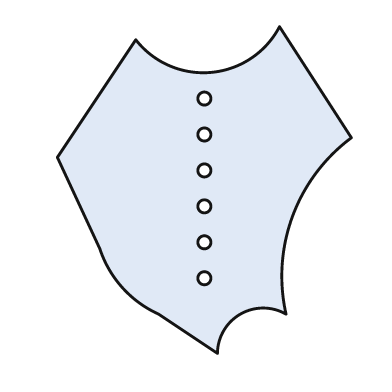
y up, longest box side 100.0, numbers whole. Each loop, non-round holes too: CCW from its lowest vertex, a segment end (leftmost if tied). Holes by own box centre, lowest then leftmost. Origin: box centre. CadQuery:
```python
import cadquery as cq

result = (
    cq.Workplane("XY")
    .moveTo(4.0, -50.0)
    .threePointArc((11.0, -38.0), (25.0, -38.0))
    .threePointArc((27.0, -8.0), (45.0, 16.0))
    .lineTo(23.0, 50.0)
    .threePointArc((2.0, 36.0), (-21.0, 46.0))
    .lineTo(-45.0, 10.0)
    .lineTo(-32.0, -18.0)
    .threePointArc((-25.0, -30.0), (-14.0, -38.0))
    .close()
    .moveTo(0.0, -27.0)
    .circle(2.0)
    .moveTo(0.0, -16.0)
    .circle(2.0)
    .moveTo(0.0, -5.0)
    .circle(2.0)
    .moveTo(0.0, 6.0)
    .circle(2.0)
    .moveTo(0.0, 17.0)
    .circle(2.0)
    .moveTo(0.0, 28.0)
    .circle(2.0)
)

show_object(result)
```